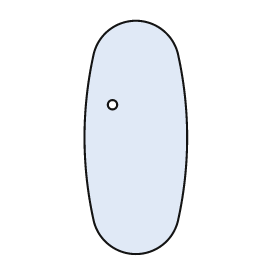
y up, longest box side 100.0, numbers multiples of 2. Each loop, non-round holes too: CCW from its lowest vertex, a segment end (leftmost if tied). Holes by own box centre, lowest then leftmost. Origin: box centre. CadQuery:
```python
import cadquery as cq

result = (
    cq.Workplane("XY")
    .moveTo(-18.0, -36.0)
    .threePointArc((0.0, -50.0), (18.0, -36.0))
    .threePointArc((22.0, 0.0), (18.0, 36.0))
    .threePointArc((0.0, 50.0), (-18.0, 36.0))
    .threePointArc((-22.0, 0.0), (-18.0, -36.0))
    .close()
    .moveTo(-10.0, 14.0)
    .circle(2.0)
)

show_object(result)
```